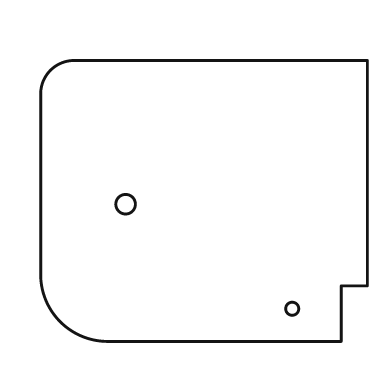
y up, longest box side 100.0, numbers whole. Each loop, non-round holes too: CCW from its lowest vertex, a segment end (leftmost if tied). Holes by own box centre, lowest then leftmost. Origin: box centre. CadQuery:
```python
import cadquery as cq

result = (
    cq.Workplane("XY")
    .moveTo(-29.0, -43.0)
    .lineTo(42.0, -43.0)
    .lineTo(42.0, -26.0)
    .lineTo(50.0, -26.0)
    .lineTo(50.0, 43.0)
    .lineTo(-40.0, 43.0)
    .threePointArc((-47.0, 40.0), (-50.0, 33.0))
    .lineTo(-50.0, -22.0)
    .threePointArc((-44.0, -37.0), (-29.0, -43.0))
    .close()
    .moveTo(27.0, -33.0)
    .circle(2.0)
    .moveTo(-24.0, -1.0)
    .circle(3.0)
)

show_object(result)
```